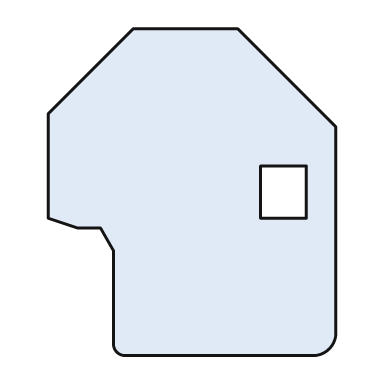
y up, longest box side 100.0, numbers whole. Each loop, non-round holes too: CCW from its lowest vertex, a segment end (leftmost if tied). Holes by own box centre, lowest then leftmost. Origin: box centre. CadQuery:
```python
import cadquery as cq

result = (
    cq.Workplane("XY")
    .moveTo(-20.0, -50.0)
    .lineTo(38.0, -50.0)
    .threePointArc((42.0, -48.0), (44.0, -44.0))
    .lineTo(44.0, 20.0)
    .lineTo(14.0, 50.0)
    .lineTo(-18.0, 50.0)
    .lineTo(-44.0, 24.0)
    .lineTo(-44.0, -8.0)
    .lineTo(-35.0, -11.0)
    .lineTo(-28.0, -11.0)
    .lineTo(-24.0, -18.0)
    .lineTo(-24.0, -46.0)
    .threePointArc((-23.0, -49.0), (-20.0, -50.0))
    .close()
    .moveTo(21.0, -8.0)
    .lineTo(35.0, -8.0)
    .lineTo(35.0, 8.0)
    .lineTo(21.0, 8.0)
    .close()
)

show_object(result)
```